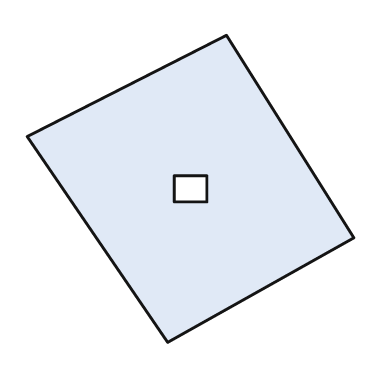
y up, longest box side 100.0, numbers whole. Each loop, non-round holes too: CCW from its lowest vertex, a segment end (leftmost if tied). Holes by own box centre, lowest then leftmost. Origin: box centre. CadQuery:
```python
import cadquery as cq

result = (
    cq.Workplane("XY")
    .moveTo(-7.0, -47.0)
    .lineTo(50.0, -15.0)
    .lineTo(11.0, 47.0)
    .lineTo(-50.0, 16.0)
    .close()
    .moveTo(-5.0, -4.0)
    .lineTo(5.0, -4.0)
    .lineTo(5.0, 4.0)
    .lineTo(-5.0, 4.0)
    .close()
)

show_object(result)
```